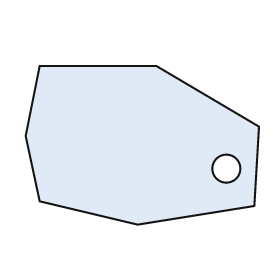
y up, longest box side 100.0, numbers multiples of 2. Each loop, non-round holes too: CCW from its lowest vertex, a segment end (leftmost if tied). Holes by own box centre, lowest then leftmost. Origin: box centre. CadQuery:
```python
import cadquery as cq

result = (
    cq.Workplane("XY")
    .moveTo(-2.0, -34.0)
    .lineTo(48.0, -26.0)
    .lineTo(50.0, 8.0)
    .lineTo(6.0, 34.0)
    .lineTo(-44.0, 34.0)
    .lineTo(-50.0, 4.0)
    .lineTo(-44.0, -24.0)
    .close()
    .moveTo(36.0, -10.0)
    .circle(6.0)
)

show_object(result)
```